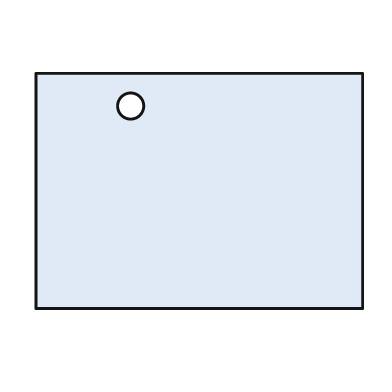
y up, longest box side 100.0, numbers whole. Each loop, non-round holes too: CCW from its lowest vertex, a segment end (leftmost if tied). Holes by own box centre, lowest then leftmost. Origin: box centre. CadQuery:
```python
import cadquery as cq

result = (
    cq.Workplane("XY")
    .moveTo(-50.0, -36.0)
    .lineTo(50.0, -36.0)
    .lineTo(50.0, 36.0)
    .lineTo(-50.0, 36.0)
    .close()
    .moveTo(-21.0, 26.0)
    .circle(4.0)
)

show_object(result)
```